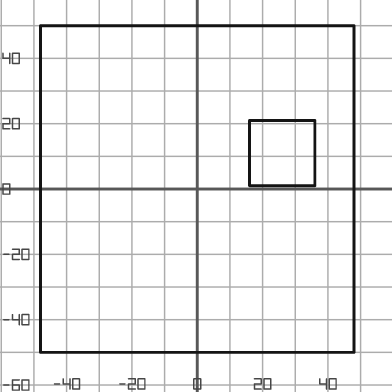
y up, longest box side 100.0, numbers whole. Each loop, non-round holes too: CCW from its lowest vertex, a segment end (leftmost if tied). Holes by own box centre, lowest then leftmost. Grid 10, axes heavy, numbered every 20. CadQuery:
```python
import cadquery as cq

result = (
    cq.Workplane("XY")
    .moveTo(-48.0, -50.0)
    .lineTo(48.0, -50.0)
    .lineTo(48.0, 50.0)
    .lineTo(-48.0, 50.0)
    .close()
    .moveTo(16.0, 1.0)
    .lineTo(36.0, 1.0)
    .lineTo(36.0, 21.0)
    .lineTo(16.0, 21.0)
    .close()
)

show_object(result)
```